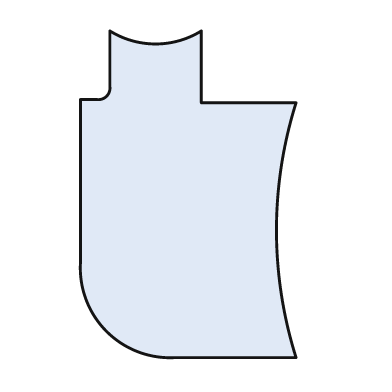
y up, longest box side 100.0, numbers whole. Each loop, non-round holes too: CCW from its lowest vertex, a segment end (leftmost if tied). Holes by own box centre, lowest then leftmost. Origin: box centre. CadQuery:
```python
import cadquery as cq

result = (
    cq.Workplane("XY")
    .moveTo(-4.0, -50.0)
    .lineTo(33.0, -50.0)
    .threePointArc((27.0, -11.0), (33.0, 28.0))
    .lineTo(4.0, 28.0)
    .lineTo(4.0, 50.0)
    .threePointArc((-10.0, 46.0), (-24.0, 50.0))
    .lineTo(-24.0, 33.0)
    .threePointArc((-25.0, 30.0), (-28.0, 29.0))
    .lineTo(-33.0, 29.0)
    .lineTo(-33.0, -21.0)
    .threePointArc((-25.0, -42.0), (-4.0, -50.0))
    .close()
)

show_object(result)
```